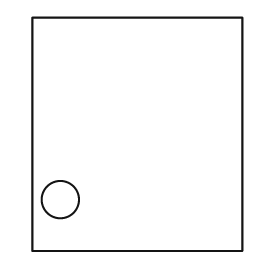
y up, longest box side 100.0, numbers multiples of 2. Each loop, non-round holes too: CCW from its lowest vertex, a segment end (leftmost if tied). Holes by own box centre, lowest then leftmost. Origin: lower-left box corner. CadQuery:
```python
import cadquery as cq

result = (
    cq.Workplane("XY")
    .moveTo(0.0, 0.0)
    .lineTo(90.0, 0.0)
    .lineTo(90.0, 100.0)
    .lineTo(0.0, 100.0)
    .close()
    .moveTo(12.0, 22.0)
    .circle(8.0)
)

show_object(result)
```